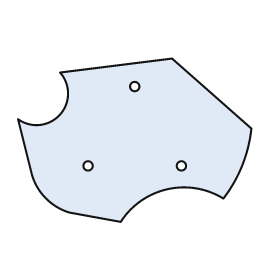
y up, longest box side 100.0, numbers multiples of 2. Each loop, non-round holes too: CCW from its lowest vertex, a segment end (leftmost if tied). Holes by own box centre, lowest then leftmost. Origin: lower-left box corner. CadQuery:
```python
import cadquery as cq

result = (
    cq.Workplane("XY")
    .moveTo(44.0, 0.0)
    .threePointArc((64.0, 14.0), (88.0, 10.0))
    .threePointArc((96.0, 24.0), (100.0, 40.0))
    .lineTo(66.0, 70.0)
    .lineTo(18.0, 64.0)
    .threePointArc((18.0, 46.0), (0.0, 44.0))
    .lineTo(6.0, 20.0)
    .threePointArc((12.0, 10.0), (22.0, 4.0))
    .close()
    .moveTo(30.0, 24.0)
    .circle(2.0)
    .moveTo(70.0, 24.0)
    .circle(2.0)
    .moveTo(50.0, 58.0)
    .circle(2.0)
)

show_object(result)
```